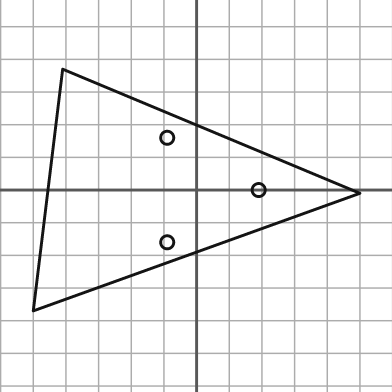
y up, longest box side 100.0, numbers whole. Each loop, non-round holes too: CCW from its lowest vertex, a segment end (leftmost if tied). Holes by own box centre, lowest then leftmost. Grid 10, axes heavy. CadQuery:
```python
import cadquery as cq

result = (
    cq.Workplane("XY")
    .moveTo(-50.0, -37.0)
    .lineTo(50.0, -1.0)
    .lineTo(-41.0, 37.0)
    .close()
    .moveTo(-9.0, -16.0)
    .circle(2.0)
    .moveTo(19.0, 0.0)
    .circle(2.0)
    .moveTo(-9.0, 16.0)
    .circle(2.0)
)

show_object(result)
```